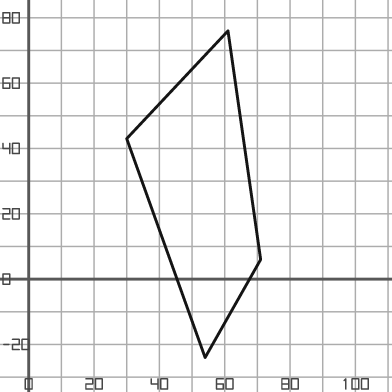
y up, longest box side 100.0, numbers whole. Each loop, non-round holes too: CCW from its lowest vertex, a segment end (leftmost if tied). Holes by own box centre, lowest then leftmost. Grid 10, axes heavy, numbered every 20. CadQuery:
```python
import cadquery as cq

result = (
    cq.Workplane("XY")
    .moveTo(54.0, -24.0)
    .lineTo(71.0, 6.0)
    .lineTo(61.0, 76.0)
    .lineTo(30.0, 43.0)
    .close()
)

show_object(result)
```